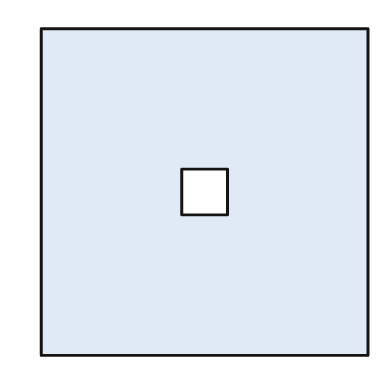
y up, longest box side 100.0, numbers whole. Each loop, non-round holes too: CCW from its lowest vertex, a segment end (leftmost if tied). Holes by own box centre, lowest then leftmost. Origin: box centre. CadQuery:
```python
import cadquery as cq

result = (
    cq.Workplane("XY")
    .moveTo(-50.0, -50.0)
    .lineTo(50.0, -50.0)
    .lineTo(50.0, 50.0)
    .lineTo(-50.0, 50.0)
    .close()
    .moveTo(-7.0, -7.0)
    .lineTo(7.0, -7.0)
    .lineTo(7.0, 7.0)
    .lineTo(-7.0, 7.0)
    .close()
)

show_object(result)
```